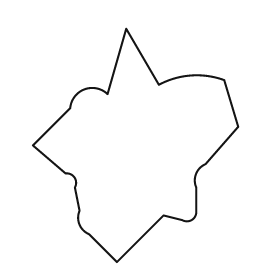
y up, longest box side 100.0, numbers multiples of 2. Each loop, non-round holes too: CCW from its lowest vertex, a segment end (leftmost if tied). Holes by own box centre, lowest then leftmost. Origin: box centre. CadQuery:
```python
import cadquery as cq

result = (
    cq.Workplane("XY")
    .moveTo(-8.0, -50.0)
    .lineTo(12.0, -30.0)
    .lineTo(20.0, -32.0)
    .threePointArc((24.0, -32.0), (26.0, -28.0))
    .lineTo(26.0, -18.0)
    .threePointArc((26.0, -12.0), (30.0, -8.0))
    .lineTo(44.0, 8.0)
    .lineTo(38.0, 28.0)
    .threePointArc((24.0, 30.0), (10.0, 26.0))
    .lineTo(-4.0, 50.0)
    .lineTo(-12.0, 22.0)
    .threePointArc((-22.0, 24.0), (-28.0, 16.0))
    .lineTo(-44.0, 0.0)
    .lineTo(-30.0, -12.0)
    .threePointArc((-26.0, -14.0), (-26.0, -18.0))
    .lineTo(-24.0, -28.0)
    .threePointArc((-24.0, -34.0), (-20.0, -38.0))
    .close()
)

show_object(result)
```